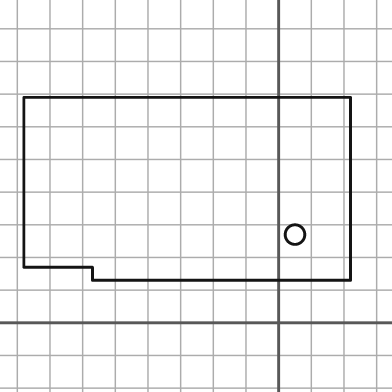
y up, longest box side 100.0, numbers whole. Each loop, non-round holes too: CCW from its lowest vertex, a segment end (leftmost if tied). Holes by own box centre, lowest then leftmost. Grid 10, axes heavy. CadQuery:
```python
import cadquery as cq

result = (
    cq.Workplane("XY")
    .moveTo(-57.0, 13.0)
    .lineTo(22.0, 13.0)
    .lineTo(22.0, 69.0)
    .lineTo(-78.0, 69.0)
    .lineTo(-78.0, 17.0)
    .lineTo(-57.0, 17.0)
    .close()
    .moveTo(5.0, 27.0)
    .circle(3.0)
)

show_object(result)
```